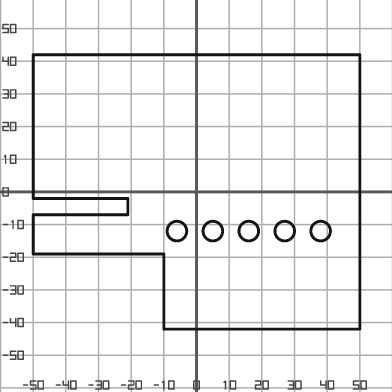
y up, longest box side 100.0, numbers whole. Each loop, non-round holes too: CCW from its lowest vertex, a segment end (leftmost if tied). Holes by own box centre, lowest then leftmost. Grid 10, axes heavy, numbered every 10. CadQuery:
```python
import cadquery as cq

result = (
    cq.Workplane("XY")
    .moveTo(-10.0, -42.0)
    .lineTo(50.0, -42.0)
    .lineTo(50.0, 42.0)
    .lineTo(-50.0, 42.0)
    .lineTo(-50.0, -2.0)
    .lineTo(-21.0, -2.0)
    .lineTo(-21.0, -7.0)
    .lineTo(-50.0, -7.0)
    .lineTo(-50.0, -19.0)
    .lineTo(-10.0, -19.0)
    .close()
    .moveTo(-6.0, -12.0)
    .circle(3.0)
    .moveTo(5.0, -12.0)
    .circle(3.0)
    .moveTo(16.0, -12.0)
    .circle(3.0)
    .moveTo(27.0, -12.0)
    .circle(3.0)
    .moveTo(38.0, -12.0)
    .circle(3.0)
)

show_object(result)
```